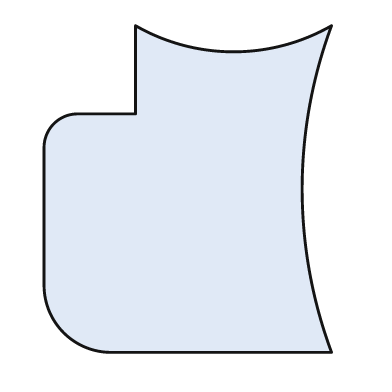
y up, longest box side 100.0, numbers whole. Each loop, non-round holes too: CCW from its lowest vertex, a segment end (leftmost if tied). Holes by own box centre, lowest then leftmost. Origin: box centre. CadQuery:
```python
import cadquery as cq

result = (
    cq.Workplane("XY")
    .moveTo(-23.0, -50.0)
    .lineTo(44.0, -50.0)
    .threePointArc((35.0, 0.0), (44.0, 50.0))
    .threePointArc((14.0, 42.0), (-16.0, 50.0))
    .lineTo(-16.0, 23.0)
    .lineTo(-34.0, 23.0)
    .threePointArc((-41.0, 20.0), (-44.0, 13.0))
    .lineTo(-44.0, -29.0)
    .threePointArc((-38.0, -44.0), (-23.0, -50.0))
    .close()
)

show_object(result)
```